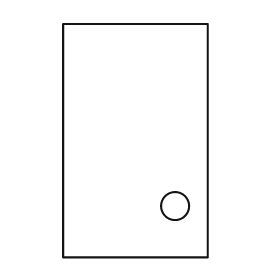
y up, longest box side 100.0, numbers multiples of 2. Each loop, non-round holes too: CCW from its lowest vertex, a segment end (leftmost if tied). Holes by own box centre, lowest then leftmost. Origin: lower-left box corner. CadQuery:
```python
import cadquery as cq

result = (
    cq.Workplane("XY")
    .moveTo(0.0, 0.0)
    .lineTo(62.0, 0.0)
    .lineTo(62.0, 100.0)
    .lineTo(0.0, 100.0)
    .close()
    .moveTo(48.0, 22.0)
    .circle(6.0)
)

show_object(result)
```